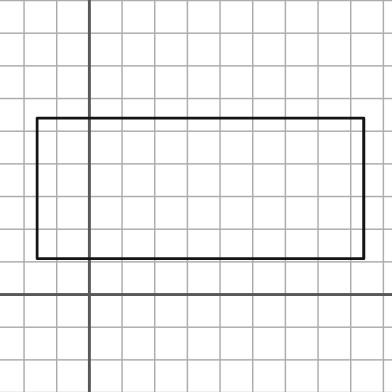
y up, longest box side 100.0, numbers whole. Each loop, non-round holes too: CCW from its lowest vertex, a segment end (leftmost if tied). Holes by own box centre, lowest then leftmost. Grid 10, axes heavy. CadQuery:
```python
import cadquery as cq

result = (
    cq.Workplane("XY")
    .moveTo(-16.0, 11.0)
    .lineTo(84.0, 11.0)
    .lineTo(84.0, 54.0)
    .lineTo(-16.0, 54.0)
    .close()
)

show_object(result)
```